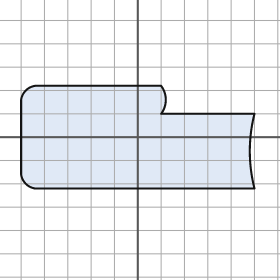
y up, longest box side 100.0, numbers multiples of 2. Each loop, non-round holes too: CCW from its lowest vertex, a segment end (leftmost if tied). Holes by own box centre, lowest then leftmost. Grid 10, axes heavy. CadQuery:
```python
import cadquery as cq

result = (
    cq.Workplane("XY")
    .moveTo(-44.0, -22.0)
    .lineTo(50.0, -22.0)
    .threePointArc((48.0, -6.0), (50.0, 10.0))
    .lineTo(10.0, 10.0)
    .threePointArc((12.0, 16.0), (10.0, 22.0))
    .lineTo(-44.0, 22.0)
    .threePointArc((-48.0, 20.0), (-50.0, 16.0))
    .lineTo(-50.0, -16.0)
    .threePointArc((-48.0, -20.0), (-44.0, -22.0))
    .close()
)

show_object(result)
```